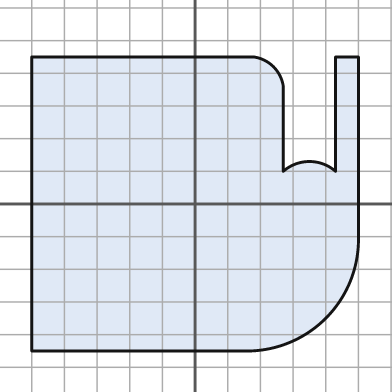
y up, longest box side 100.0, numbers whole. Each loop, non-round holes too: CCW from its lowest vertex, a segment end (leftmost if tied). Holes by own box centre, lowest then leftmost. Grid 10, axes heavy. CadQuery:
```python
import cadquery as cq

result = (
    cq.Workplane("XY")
    .moveTo(-50.0, -45.0)
    .lineTo(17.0, -45.0)
    .threePointArc((40.0, -35.0), (50.0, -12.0))
    .lineTo(50.0, 45.0)
    .lineTo(43.0, 45.0)
    .lineTo(43.0, 10.0)
    .threePointArc((35.0, 13.0), (27.0, 10.0))
    .lineTo(27.0, 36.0)
    .threePointArc((24.0, 42.0), (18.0, 45.0))
    .lineTo(-50.0, 45.0)
    .close()
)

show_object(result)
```